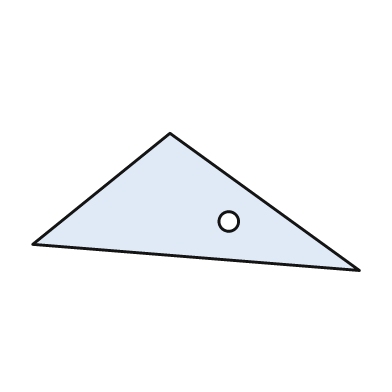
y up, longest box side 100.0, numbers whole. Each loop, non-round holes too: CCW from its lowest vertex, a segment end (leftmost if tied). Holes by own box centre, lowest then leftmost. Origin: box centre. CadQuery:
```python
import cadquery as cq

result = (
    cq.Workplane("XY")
    .moveTo(50.0, -21.0)
    .lineTo(-8.0, 21.0)
    .lineTo(-50.0, -13.0)
    .close()
    .moveTo(10.0, -6.0)
    .circle(3.0)
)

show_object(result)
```